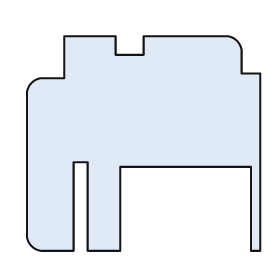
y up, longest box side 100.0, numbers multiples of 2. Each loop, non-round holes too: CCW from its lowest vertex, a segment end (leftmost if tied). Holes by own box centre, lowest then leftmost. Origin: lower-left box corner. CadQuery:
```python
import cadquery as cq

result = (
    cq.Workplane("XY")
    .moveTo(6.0, 0.0)
    .lineTo(20.0, 0.0)
    .lineTo(20.0, 38.0)
    .lineTo(26.0, 38.0)
    .lineTo(26.0, 0.0)
    .lineTo(40.0, 0.0)
    .lineTo(40.0, 36.0)
    .lineTo(96.0, 36.0)
    .lineTo(96.0, 0.0)
    .lineTo(100.0, 0.0)
    .lineTo(100.0, 76.0)
    .lineTo(92.0, 76.0)
    .lineTo(92.0, 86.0)
    .threePointArc((90.0, 90.0), (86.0, 92.0))
    .lineTo(50.0, 92.0)
    .lineTo(50.0, 84.0)
    .lineTo(38.0, 84.0)
    .lineTo(38.0, 92.0)
    .lineTo(16.0, 92.0)
    .lineTo(16.0, 74.0)
    .lineTo(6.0, 74.0)
    .threePointArc((2.0, 72.0), (0.0, 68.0))
    .lineTo(0.0, 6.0)
    .threePointArc((2.0, 2.0), (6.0, 0.0))
    .close()
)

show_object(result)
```